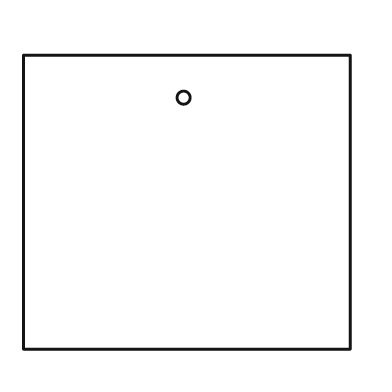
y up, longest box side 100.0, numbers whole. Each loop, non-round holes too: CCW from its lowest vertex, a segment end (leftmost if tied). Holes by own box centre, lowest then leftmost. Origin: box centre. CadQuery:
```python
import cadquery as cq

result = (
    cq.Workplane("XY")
    .moveTo(-50.0, -45.0)
    .lineTo(50.0, -45.0)
    .lineTo(50.0, 45.0)
    .lineTo(-50.0, 45.0)
    .close()
    .moveTo(-1.0, 32.0)
    .circle(2.0)
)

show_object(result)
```